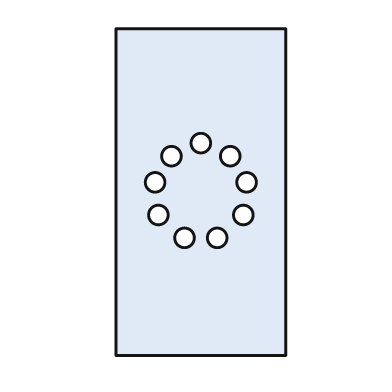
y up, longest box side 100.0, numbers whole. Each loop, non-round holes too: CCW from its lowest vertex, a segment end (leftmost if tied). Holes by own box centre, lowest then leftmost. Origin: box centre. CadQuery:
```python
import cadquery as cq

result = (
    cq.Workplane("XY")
    .moveTo(-26.0, -50.0)
    .lineTo(26.0, -50.0)
    .lineTo(26.0, 50.0)
    .lineTo(-26.0, 50.0)
    .close()
    .moveTo(-5.0, -14.0)
    .circle(3.0)
    .moveTo(5.0, -14.0)
    .circle(3.0)
    .moveTo(-13.0, -7.0)
    .circle(3.0)
    .moveTo(13.0, -7.0)
    .circle(3.0)
    .moveTo(-14.0, 3.0)
    .circle(3.0)
    .moveTo(14.0, 3.0)
    .circle(3.0)
    .moveTo(-9.0, 11.0)
    .circle(3.0)
    .moveTo(9.0, 11.0)
    .circle(3.0)
    .moveTo(0.0, 15.0)
    .circle(3.0)
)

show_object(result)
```